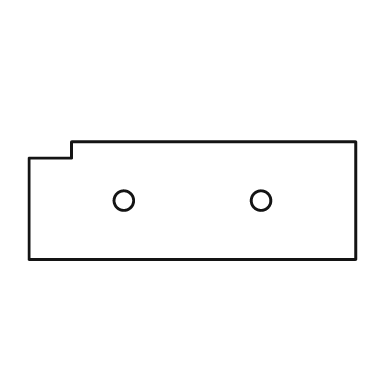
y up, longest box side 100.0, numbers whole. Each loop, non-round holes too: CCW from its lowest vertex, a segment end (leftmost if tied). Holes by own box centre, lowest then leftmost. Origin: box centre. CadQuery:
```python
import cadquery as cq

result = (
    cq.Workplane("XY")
    .moveTo(-50.0, -18.0)
    .lineTo(50.0, -18.0)
    .lineTo(50.0, 18.0)
    .lineTo(-37.0, 18.0)
    .lineTo(-37.0, 13.0)
    .lineTo(-50.0, 13.0)
    .close()
    .moveTo(-21.0, 0.0)
    .circle(3.0)
    .moveTo(21.0, 0.0)
    .circle(3.0)
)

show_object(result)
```